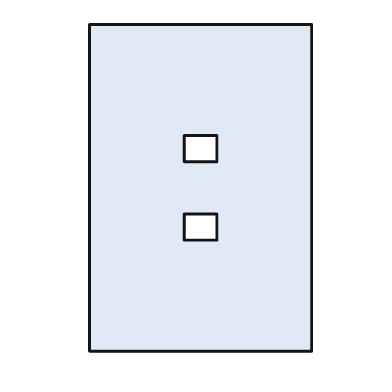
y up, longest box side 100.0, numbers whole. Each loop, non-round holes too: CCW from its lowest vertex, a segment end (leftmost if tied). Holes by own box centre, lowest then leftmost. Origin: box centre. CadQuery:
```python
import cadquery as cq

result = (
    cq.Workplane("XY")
    .moveTo(-34.0, -50.0)
    .lineTo(34.0, -50.0)
    .lineTo(34.0, 50.0)
    .lineTo(-34.0, 50.0)
    .close()
    .moveTo(-5.0, -16.0)
    .lineTo(5.0, -16.0)
    .lineTo(5.0, -8.0)
    .lineTo(-5.0, -8.0)
    .close()
    .moveTo(-5.0, 8.0)
    .lineTo(5.0, 8.0)
    .lineTo(5.0, 16.0)
    .lineTo(-5.0, 16.0)
    .close()
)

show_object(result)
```